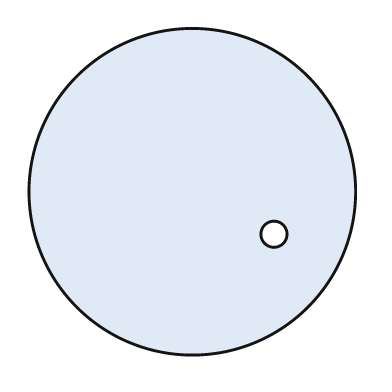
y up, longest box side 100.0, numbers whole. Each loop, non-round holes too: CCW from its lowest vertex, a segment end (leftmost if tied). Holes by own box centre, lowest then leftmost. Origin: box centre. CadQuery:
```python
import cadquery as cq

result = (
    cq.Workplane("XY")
    .moveTo(0.0, 0.0)
    .circle(50.0)
    .moveTo(25.0, -13.0)
    .circle(4.0)
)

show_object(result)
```